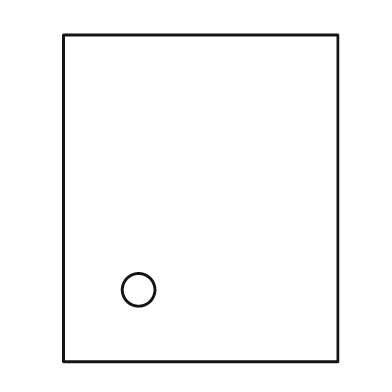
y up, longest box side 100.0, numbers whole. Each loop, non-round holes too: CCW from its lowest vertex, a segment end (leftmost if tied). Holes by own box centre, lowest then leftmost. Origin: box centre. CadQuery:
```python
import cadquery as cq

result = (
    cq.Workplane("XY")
    .moveTo(-42.0, -50.0)
    .lineTo(42.0, -50.0)
    .lineTo(42.0, 50.0)
    .lineTo(-42.0, 50.0)
    .close()
    .moveTo(-19.0, -28.0)
    .circle(5.0)
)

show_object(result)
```